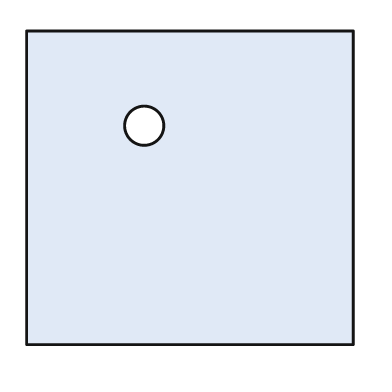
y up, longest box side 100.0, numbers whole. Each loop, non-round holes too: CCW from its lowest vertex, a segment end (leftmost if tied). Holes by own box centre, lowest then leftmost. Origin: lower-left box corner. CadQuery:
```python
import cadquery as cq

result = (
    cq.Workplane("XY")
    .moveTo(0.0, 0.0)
    .lineTo(100.0, 0.0)
    .lineTo(100.0, 96.0)
    .lineTo(0.0, 96.0)
    .close()
    .moveTo(36.0, 67.0)
    .circle(6.0)
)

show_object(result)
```